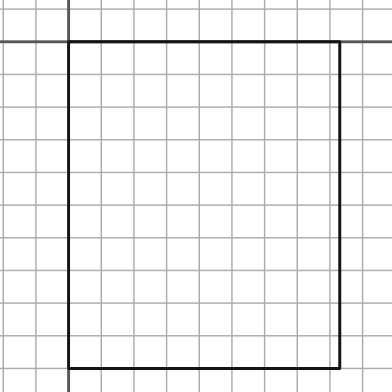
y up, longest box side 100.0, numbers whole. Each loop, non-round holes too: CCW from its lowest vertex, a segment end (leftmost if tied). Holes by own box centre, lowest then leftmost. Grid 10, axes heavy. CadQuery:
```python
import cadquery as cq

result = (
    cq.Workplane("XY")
    .moveTo(0.0, -100.0)
    .lineTo(83.0, -100.0)
    .lineTo(83.0, 0.0)
    .lineTo(0.0, 0.0)
    .close()
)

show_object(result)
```